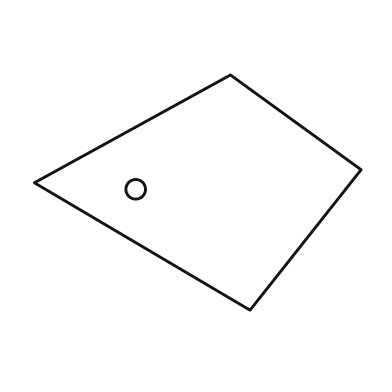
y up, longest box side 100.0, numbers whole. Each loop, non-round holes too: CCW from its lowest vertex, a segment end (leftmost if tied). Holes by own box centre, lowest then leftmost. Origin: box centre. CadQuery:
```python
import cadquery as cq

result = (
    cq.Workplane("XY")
    .moveTo(16.0, -36.0)
    .lineTo(50.0, 7.0)
    .lineTo(10.0, 36.0)
    .lineTo(-50.0, 3.0)
    .close()
    .moveTo(-19.0, 1.0)
    .circle(3.0)
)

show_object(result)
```